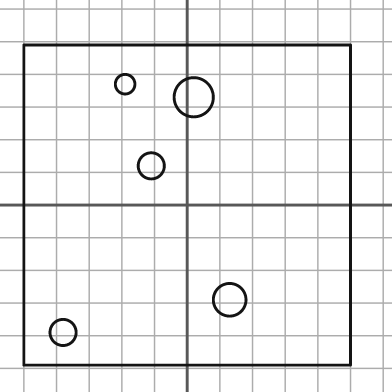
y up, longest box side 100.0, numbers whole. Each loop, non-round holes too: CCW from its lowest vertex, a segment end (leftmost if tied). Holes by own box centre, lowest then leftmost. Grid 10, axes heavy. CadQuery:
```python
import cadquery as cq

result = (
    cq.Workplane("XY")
    .moveTo(-50.0, -49.0)
    .lineTo(50.0, -49.0)
    .lineTo(50.0, 49.0)
    .lineTo(-50.0, 49.0)
    .close()
    .moveTo(-38.0, -39.0)
    .circle(4.0)
    .moveTo(13.0, -29.0)
    .circle(5.0)
    .moveTo(-11.0, 12.0)
    .circle(4.0)
    .moveTo(2.0, 33.0)
    .circle(6.0)
    .moveTo(-19.0, 37.0)
    .circle(3.0)
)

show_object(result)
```